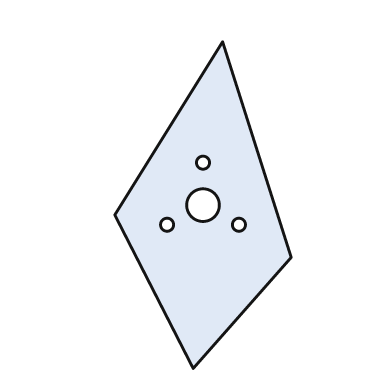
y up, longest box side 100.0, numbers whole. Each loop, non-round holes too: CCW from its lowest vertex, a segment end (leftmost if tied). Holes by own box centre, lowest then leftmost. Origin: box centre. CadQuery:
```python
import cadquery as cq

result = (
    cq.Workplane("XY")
    .moveTo(-3.0, -50.0)
    .lineTo(27.0, -16.0)
    .lineTo(6.0, 50.0)
    .lineTo(-27.0, -3.0)
    .close()
    .moveTo(-11.0, -6.0)
    .circle(2.0)
    .moveTo(11.0, -6.0)
    .circle(2.0)
    .moveTo(0.0, 0.0)
    .circle(5.0)
    .moveTo(0.0, 13.0)
    .circle(2.0)
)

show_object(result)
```